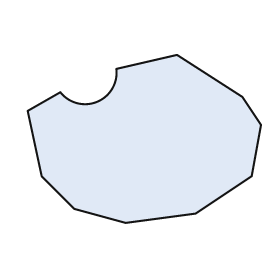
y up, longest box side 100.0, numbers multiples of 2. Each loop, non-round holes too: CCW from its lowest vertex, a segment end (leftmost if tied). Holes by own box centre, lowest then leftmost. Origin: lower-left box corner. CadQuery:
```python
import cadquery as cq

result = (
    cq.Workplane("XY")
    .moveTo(42.0, 0.0)
    .lineTo(72.0, 4.0)
    .lineTo(96.0, 20.0)
    .lineTo(100.0, 42.0)
    .lineTo(92.0, 54.0)
    .lineTo(64.0, 72.0)
    .lineTo(38.0, 66.0)
    .threePointArc((30.0, 52.0), (14.0, 56.0))
    .lineTo(0.0, 48.0)
    .lineTo(6.0, 20.0)
    .lineTo(20.0, 6.0)
    .close()
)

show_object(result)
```